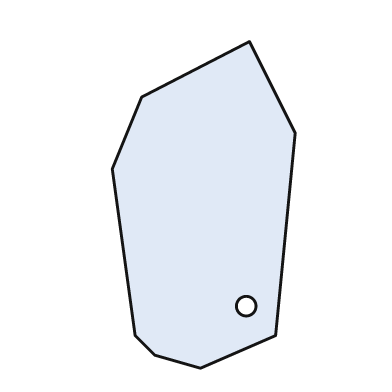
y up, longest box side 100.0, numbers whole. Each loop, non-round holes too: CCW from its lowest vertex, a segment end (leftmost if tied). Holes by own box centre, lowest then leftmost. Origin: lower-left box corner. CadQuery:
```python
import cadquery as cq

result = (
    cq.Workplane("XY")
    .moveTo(27.0, 0.0)
    .lineTo(50.0, 10.0)
    .lineTo(56.0, 72.0)
    .lineTo(42.0, 100.0)
    .lineTo(9.0, 83.0)
    .lineTo(0.0, 61.0)
    .lineTo(7.0, 10.0)
    .lineTo(13.0, 4.0)
    .close()
    .moveTo(41.0, 19.0)
    .circle(3.0)
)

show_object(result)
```